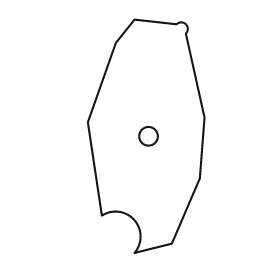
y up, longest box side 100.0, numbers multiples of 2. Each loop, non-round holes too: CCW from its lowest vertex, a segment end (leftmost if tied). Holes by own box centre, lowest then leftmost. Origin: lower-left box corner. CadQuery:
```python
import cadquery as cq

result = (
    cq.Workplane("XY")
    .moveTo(20.0, 0.0)
    .lineTo(36.0, 4.0)
    .lineTo(48.0, 32.0)
    .lineTo(50.0, 58.0)
    .lineTo(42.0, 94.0)
    .threePointArc((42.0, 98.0), (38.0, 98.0))
    .lineTo(20.0, 100.0)
    .lineTo(12.0, 90.0)
    .lineTo(0.0, 56.0)
    .lineTo(6.0, 16.0)
    .threePointArc((20.0, 14.0), (20.0, 0.0))
    .close()
    .moveTo(26.0, 50.0)
    .circle(4.0)
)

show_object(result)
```